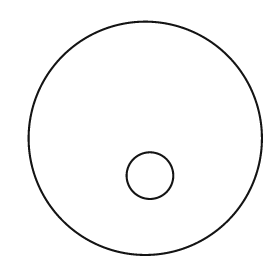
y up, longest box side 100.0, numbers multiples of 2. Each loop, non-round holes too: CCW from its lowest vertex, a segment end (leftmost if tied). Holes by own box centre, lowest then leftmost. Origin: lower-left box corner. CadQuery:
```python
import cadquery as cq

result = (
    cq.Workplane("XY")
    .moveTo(50.0, 50.0)
    .circle(50.0)
    .moveTo(52.0, 34.0)
    .circle(10.0)
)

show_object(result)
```